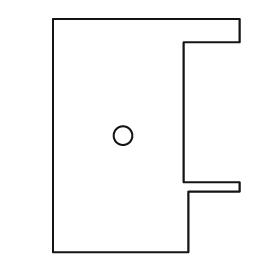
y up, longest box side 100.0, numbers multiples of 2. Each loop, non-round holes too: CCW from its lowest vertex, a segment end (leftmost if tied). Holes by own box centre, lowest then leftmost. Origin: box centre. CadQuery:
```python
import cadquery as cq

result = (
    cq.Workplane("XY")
    .moveTo(-40.0, -50.0)
    .lineTo(18.0, -50.0)
    .lineTo(18.0, -24.0)
    .lineTo(40.0, -24.0)
    .lineTo(40.0, -20.0)
    .lineTo(16.0, -20.0)
    .lineTo(16.0, 40.0)
    .lineTo(40.0, 40.0)
    .lineTo(40.0, 50.0)
    .lineTo(-40.0, 50.0)
    .close()
    .moveTo(-10.0, 0.0)
    .circle(4.0)
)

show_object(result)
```